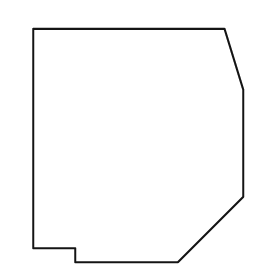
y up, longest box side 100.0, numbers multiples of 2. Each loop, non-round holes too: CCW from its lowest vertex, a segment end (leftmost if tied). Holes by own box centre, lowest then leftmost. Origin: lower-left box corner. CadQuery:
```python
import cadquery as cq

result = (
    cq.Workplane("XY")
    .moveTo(18.0, 0.0)
    .lineTo(62.0, 0.0)
    .lineTo(90.0, 28.0)
    .lineTo(90.0, 74.0)
    .lineTo(82.0, 100.0)
    .lineTo(0.0, 100.0)
    .lineTo(0.0, 6.0)
    .lineTo(18.0, 6.0)
    .close()
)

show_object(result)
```